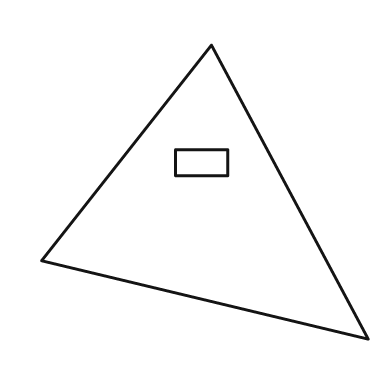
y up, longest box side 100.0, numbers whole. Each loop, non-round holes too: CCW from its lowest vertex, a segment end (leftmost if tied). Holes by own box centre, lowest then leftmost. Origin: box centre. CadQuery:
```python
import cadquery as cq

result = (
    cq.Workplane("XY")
    .moveTo(50.0, -45.0)
    .lineTo(2.0, 45.0)
    .lineTo(-50.0, -21.0)
    .close()
    .moveTo(-9.0, 5.0)
    .lineTo(7.0, 5.0)
    .lineTo(7.0, 13.0)
    .lineTo(-9.0, 13.0)
    .close()
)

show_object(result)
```